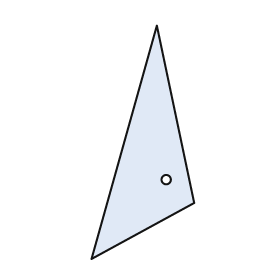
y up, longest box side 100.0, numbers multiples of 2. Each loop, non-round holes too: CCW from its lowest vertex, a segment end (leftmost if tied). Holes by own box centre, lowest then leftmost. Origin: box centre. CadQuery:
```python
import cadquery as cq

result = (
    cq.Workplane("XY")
    .moveTo(-22.0, -50.0)
    .lineTo(22.0, -26.0)
    .lineTo(6.0, 50.0)
    .close()
    .moveTo(10.0, -16.0)
    .circle(2.0)
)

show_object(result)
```